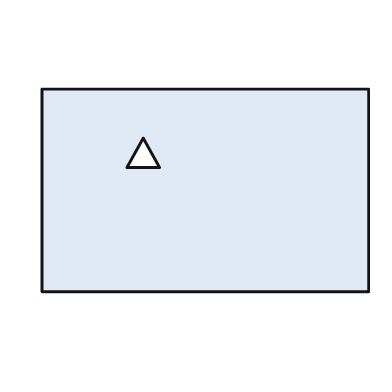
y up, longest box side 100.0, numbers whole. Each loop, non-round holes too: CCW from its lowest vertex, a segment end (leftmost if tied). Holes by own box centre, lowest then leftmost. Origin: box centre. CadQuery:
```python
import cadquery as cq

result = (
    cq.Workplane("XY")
    .moveTo(-50.0, -31.0)
    .lineTo(50.0, -31.0)
    .lineTo(50.0, 31.0)
    .lineTo(-50.0, 31.0)
    .close()
    .moveTo(-24.0, 7.0)
    .lineTo(-14.0, 7.0)
    .lineTo(-19.0, 16.0)
    .close()
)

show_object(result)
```